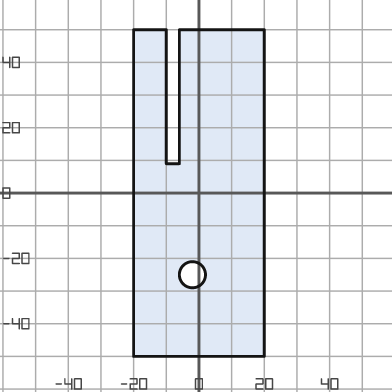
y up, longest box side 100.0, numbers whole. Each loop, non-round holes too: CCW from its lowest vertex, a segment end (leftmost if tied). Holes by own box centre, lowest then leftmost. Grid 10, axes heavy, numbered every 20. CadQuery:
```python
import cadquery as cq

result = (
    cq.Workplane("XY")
    .moveTo(-20.0, -50.0)
    .lineTo(20.0, -50.0)
    .lineTo(20.0, 50.0)
    .lineTo(-6.0, 50.0)
    .lineTo(-6.0, 9.0)
    .lineTo(-10.0, 9.0)
    .lineTo(-10.0, 50.0)
    .lineTo(-20.0, 50.0)
    .close()
    .moveTo(-2.0, -25.0)
    .circle(4.0)
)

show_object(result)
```